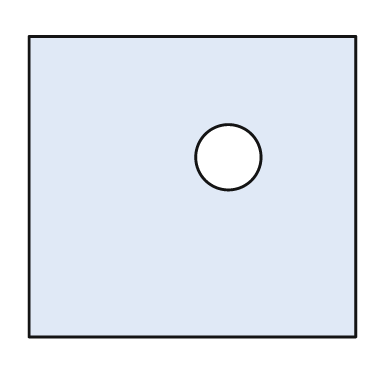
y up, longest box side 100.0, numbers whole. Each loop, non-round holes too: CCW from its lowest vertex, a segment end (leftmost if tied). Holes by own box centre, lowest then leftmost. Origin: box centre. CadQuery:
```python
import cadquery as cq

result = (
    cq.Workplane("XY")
    .moveTo(-50.0, -46.0)
    .lineTo(50.0, -46.0)
    .lineTo(50.0, 46.0)
    .lineTo(-50.0, 46.0)
    .close()
    .moveTo(11.0, 9.0)
    .circle(10.0)
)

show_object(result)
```